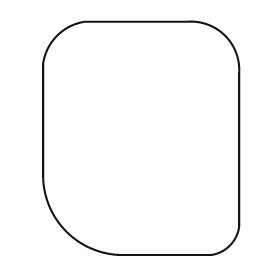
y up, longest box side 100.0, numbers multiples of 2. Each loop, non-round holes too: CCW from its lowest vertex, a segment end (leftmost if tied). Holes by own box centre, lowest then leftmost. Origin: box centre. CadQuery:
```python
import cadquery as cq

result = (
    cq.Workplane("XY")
    .moveTo(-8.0, -50.0)
    .lineTo(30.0, -50.0)
    .threePointArc((38.0, -46.0), (42.0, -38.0))
    .lineTo(42.0, 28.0)
    .threePointArc((36.0, 44.0), (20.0, 50.0))
    .lineTo(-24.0, 50.0)
    .threePointArc((-36.0, 44.0), (-42.0, 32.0))
    .lineTo(-42.0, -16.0)
    .threePointArc((-32.0, -40.0), (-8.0, -50.0))
    .close()
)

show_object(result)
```